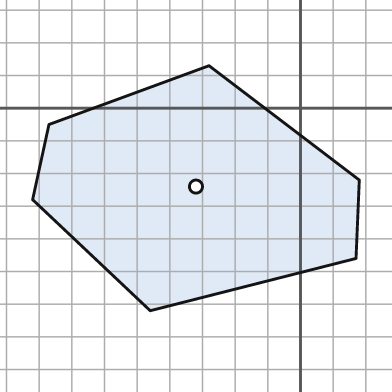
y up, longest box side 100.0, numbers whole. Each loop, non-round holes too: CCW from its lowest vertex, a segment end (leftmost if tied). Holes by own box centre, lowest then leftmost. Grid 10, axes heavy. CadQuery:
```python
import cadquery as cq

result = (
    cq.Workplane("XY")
    .moveTo(-46.0, -62.0)
    .lineTo(17.0, -46.0)
    .lineTo(18.0, -22.0)
    .lineTo(-28.0, 13.0)
    .lineTo(-77.0, -5.0)
    .lineTo(-82.0, -28.0)
    .close()
    .moveTo(-32.0, -24.0)
    .circle(2.0)
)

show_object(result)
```